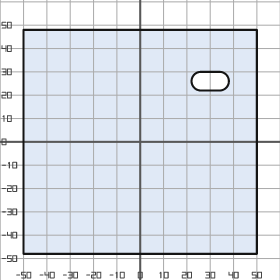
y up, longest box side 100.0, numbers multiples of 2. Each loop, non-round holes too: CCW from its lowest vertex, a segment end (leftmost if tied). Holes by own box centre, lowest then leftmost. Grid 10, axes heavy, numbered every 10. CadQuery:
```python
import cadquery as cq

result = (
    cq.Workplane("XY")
    .moveTo(-50.0, -48.0)
    .lineTo(50.0, -48.0)
    .lineTo(50.0, 48.0)
    .lineTo(-50.0, 48.0)
    .close()
    .moveTo(26.0, 22.0)
    .lineTo(34.0, 22.0)
    .threePointArc((38.0, 26.0), (34.0, 30.0))
    .lineTo(26.0, 30.0)
    .threePointArc((22.0, 26.0), (26.0, 22.0))
    .close()
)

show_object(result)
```